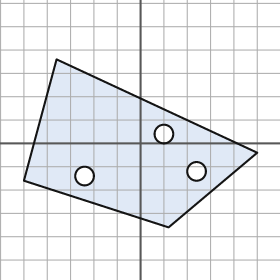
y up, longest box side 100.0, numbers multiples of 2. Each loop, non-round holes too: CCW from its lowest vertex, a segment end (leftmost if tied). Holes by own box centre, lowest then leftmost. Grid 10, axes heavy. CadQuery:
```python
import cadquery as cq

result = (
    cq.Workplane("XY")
    .moveTo(12.0, -36.0)
    .lineTo(50.0, -4.0)
    .lineTo(-36.0, 36.0)
    .lineTo(-50.0, -16.0)
    .close()
    .moveTo(-24.0, -14.0)
    .circle(4.0)
    .moveTo(24.0, -12.0)
    .circle(4.0)
    .moveTo(10.0, 4.0)
    .circle(4.0)
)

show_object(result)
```